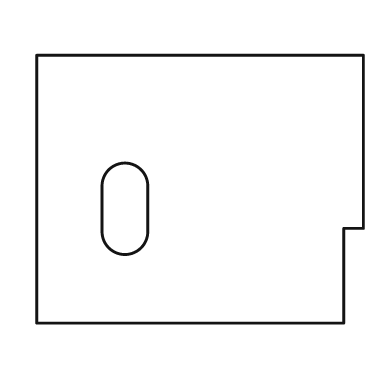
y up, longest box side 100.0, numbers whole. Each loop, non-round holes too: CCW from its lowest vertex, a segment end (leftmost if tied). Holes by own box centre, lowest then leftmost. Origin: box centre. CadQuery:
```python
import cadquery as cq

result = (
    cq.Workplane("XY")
    .moveTo(-50.0, -41.0)
    .lineTo(44.0, -41.0)
    .lineTo(44.0, -12.0)
    .lineTo(50.0, -12.0)
    .lineTo(50.0, 41.0)
    .lineTo(-50.0, 41.0)
    .close()
    .moveTo(-30.0, -13.0)
    .threePointArc((-23.0, -20.0), (-16.0, -13.0))
    .lineTo(-16.0, 1.0)
    .threePointArc((-23.0, 8.0), (-30.0, 1.0))
    .close()
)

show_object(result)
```